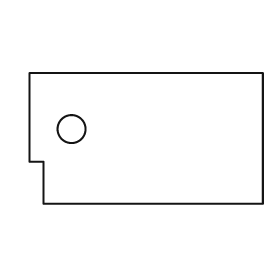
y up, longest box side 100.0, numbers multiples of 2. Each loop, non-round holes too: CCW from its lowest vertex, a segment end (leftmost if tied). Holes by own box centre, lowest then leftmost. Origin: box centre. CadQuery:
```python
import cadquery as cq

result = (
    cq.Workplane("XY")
    .moveTo(-44.0, -28.0)
    .lineTo(50.0, -28.0)
    .lineTo(50.0, 28.0)
    .lineTo(-50.0, 28.0)
    .lineTo(-50.0, -10.0)
    .lineTo(-44.0, -10.0)
    .close()
    .moveTo(-32.0, 4.0)
    .circle(6.0)
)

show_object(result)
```